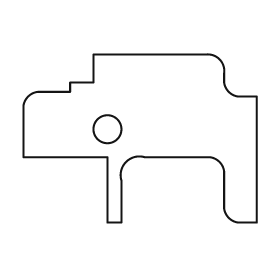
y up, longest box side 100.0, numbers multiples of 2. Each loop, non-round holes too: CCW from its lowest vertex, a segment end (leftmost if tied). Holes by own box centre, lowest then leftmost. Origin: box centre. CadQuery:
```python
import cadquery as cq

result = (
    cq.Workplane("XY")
    .moveTo(-14.0, -36.0)
    .lineTo(-8.0, -36.0)
    .lineTo(-8.0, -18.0)
    .threePointArc((-6.0, -10.0), (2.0, -8.0))
    .lineTo(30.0, -8.0)
    .threePointArc((34.0, -10.0), (36.0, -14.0))
    .lineTo(36.0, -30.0)
    .threePointArc((38.0, -34.0), (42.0, -36.0))
    .lineTo(50.0, -36.0)
    .lineTo(50.0, 18.0)
    .lineTo(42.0, 18.0)
    .threePointArc((38.0, 20.0), (36.0, 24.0))
    .lineTo(36.0, 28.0)
    .threePointArc((34.0, 34.0), (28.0, 36.0))
    .lineTo(-20.0, 36.0)
    .lineTo(-20.0, 24.0)
    .lineTo(-30.0, 24.0)
    .lineTo(-30.0, 20.0)
    .lineTo(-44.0, 20.0)
    .threePointArc((-48.0, 18.0), (-50.0, 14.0))
    .lineTo(-50.0, -8.0)
    .lineTo(-14.0, -8.0)
    .close()
    .moveTo(-14.0, 4.0)
    .circle(6.0)
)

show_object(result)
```